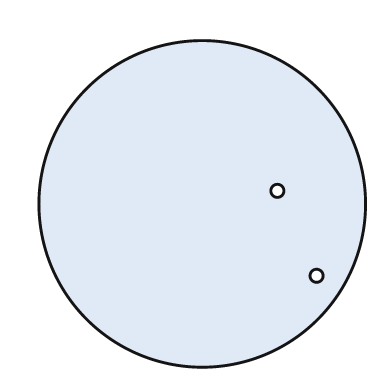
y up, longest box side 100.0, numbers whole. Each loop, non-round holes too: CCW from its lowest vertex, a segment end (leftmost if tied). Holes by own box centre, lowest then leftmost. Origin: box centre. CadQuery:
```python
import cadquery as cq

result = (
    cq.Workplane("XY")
    .moveTo(0.0, 0.0)
    .circle(50.0)
    .moveTo(35.0, -22.0)
    .circle(2.0)
    .moveTo(23.0, 4.0)
    .circle(2.0)
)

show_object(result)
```